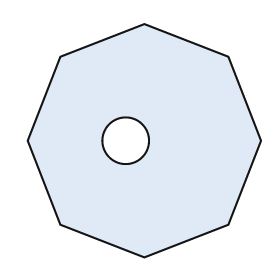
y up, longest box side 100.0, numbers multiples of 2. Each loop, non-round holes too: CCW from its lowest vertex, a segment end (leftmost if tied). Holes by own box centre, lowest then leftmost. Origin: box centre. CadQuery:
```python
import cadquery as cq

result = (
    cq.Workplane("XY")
    .moveTo(0.0, -50.0)
    .lineTo(36.0, -36.0)
    .lineTo(50.0, 0.0)
    .lineTo(36.0, 36.0)
    .lineTo(0.0, 50.0)
    .lineTo(-36.0, 36.0)
    .lineTo(-50.0, 0.0)
    .lineTo(-36.0, -36.0)
    .close()
    .moveTo(-8.0, 0.0)
    .circle(10.0)
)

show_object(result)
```